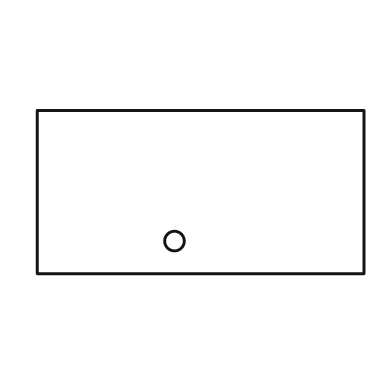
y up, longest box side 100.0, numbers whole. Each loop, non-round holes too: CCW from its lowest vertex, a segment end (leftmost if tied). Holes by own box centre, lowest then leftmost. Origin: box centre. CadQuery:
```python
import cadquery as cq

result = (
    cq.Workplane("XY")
    .moveTo(-50.0, -25.0)
    .lineTo(50.0, -25.0)
    .lineTo(50.0, 25.0)
    .lineTo(-50.0, 25.0)
    .close()
    .moveTo(-8.0, -15.0)
    .circle(3.0)
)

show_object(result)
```